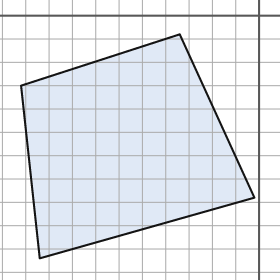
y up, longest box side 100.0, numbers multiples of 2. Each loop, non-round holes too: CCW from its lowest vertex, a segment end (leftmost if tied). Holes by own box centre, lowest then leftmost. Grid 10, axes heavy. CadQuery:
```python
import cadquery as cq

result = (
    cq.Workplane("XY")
    .moveTo(-94.0, -104.0)
    .lineTo(-2.0, -78.0)
    .lineTo(-34.0, -8.0)
    .lineTo(-102.0, -30.0)
    .close()
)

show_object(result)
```